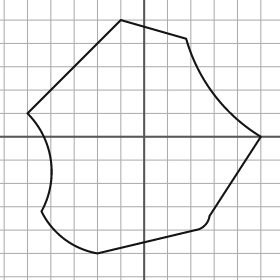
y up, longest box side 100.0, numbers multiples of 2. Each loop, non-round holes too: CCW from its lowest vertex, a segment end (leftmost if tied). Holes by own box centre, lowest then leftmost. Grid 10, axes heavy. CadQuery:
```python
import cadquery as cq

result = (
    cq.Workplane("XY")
    .moveTo(-20.0, -50.0)
    .lineTo(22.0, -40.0)
    .threePointArc((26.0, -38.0), (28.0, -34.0))
    .lineTo(50.0, 0.0)
    .threePointArc((30.0, 18.0), (18.0, 42.0))
    .lineTo(-10.0, 50.0)
    .lineTo(-50.0, 10.0)
    .threePointArc((-40.0, -10.0), (-44.0, -32.0))
    .threePointArc((-34.0, -44.0), (-20.0, -50.0))
    .close()
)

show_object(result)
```